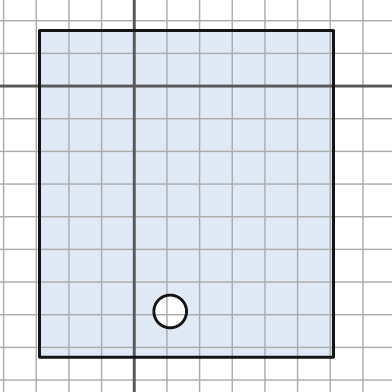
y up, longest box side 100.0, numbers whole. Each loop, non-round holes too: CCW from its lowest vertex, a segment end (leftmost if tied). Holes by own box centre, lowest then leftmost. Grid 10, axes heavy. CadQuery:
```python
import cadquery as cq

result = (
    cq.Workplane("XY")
    .moveTo(-29.0, -83.0)
    .lineTo(61.0, -83.0)
    .lineTo(61.0, 17.0)
    .lineTo(-29.0, 17.0)
    .close()
    .moveTo(11.0, -69.0)
    .circle(5.0)
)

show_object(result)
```